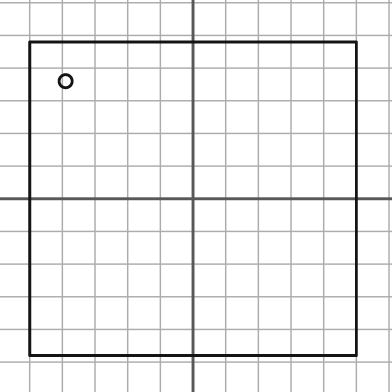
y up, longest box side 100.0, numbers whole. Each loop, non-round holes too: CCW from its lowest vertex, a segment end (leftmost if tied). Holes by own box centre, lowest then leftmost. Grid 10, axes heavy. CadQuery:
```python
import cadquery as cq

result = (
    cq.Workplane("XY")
    .moveTo(-50.0, -48.0)
    .lineTo(50.0, -48.0)
    .lineTo(50.0, 48.0)
    .lineTo(-50.0, 48.0)
    .close()
    .moveTo(-39.0, 36.0)
    .circle(2.0)
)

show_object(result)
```